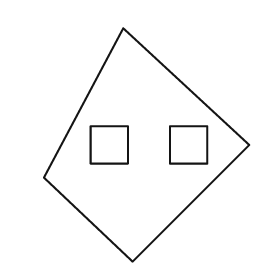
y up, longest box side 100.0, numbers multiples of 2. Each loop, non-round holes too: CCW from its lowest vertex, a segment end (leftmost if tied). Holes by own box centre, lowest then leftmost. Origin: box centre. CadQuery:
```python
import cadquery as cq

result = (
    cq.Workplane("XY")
    .moveTo(-6.0, -50.0)
    .lineTo(44.0, 0.0)
    .lineTo(-10.0, 50.0)
    .lineTo(-44.0, -14.0)
    .close()
    .moveTo(-24.0, -8.0)
    .lineTo(-8.0, -8.0)
    .lineTo(-8.0, 8.0)
    .lineTo(-24.0, 8.0)
    .close()
    .moveTo(10.0, -8.0)
    .lineTo(26.0, -8.0)
    .lineTo(26.0, 8.0)
    .lineTo(10.0, 8.0)
    .close()
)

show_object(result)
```